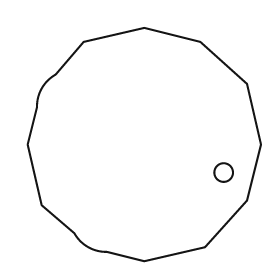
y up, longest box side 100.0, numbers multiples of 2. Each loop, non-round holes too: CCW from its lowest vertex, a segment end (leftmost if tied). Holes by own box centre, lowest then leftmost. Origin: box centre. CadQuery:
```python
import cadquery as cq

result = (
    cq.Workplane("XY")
    .moveTo(0.0, -50.0)
    .lineTo(26.0, -44.0)
    .lineTo(44.0, -24.0)
    .lineTo(50.0, 0.0)
    .lineTo(44.0, 26.0)
    .lineTo(24.0, 44.0)
    .lineTo(0.0, 50.0)
    .lineTo(-26.0, 44.0)
    .lineTo(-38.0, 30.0)
    .threePointArc((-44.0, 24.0), (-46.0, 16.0))
    .lineTo(-50.0, 0.0)
    .lineTo(-44.0, -26.0)
    .lineTo(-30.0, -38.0)
    .threePointArc((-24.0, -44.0), (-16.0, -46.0))
    .close()
    .moveTo(34.0, -12.0)
    .circle(4.0)
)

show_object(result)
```